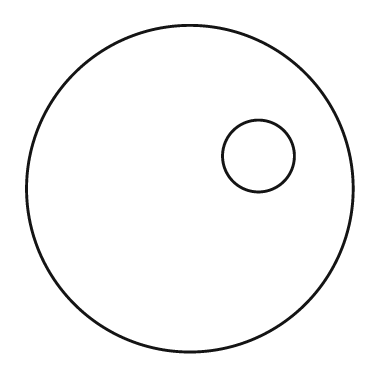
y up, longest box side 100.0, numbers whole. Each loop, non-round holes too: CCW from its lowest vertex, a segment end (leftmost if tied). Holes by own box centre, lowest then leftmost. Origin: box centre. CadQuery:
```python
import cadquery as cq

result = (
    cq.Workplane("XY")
    .moveTo(0.0, 0.0)
    .circle(50.0)
    .moveTo(21.0, 10.0)
    .circle(11.0)
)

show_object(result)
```